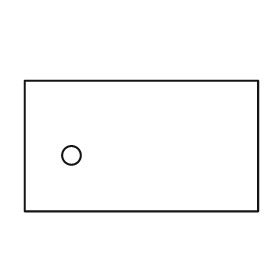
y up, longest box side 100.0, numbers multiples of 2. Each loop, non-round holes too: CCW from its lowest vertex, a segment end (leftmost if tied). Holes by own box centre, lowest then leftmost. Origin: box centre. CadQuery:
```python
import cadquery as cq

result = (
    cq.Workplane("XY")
    .moveTo(-50.0, -28.0)
    .lineTo(50.0, -28.0)
    .lineTo(50.0, 28.0)
    .lineTo(-50.0, 28.0)
    .close()
    .moveTo(-30.0, -4.0)
    .circle(4.0)
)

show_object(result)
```